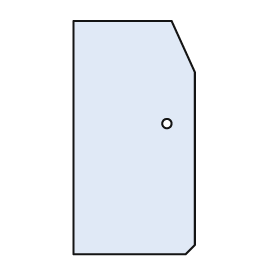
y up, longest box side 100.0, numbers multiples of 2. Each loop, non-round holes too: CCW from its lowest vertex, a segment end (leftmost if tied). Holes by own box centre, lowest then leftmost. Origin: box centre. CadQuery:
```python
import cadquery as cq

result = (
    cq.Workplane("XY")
    .moveTo(-26.0, -50.0)
    .lineTo(22.0, -50.0)
    .lineTo(26.0, -46.0)
    .lineTo(26.0, 28.0)
    .lineTo(16.0, 50.0)
    .lineTo(-26.0, 50.0)
    .close()
    .moveTo(14.0, 6.0)
    .circle(2.0)
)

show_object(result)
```